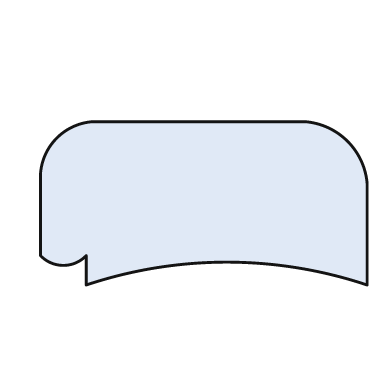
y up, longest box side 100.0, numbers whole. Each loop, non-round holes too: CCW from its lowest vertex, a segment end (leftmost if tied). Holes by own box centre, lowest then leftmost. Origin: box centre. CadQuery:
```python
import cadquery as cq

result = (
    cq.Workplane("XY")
    .moveTo(-36.0, -25.0)
    .threePointArc((7.0, -18.0), (50.0, -25.0))
    .lineTo(50.0, 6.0)
    .threePointArc((44.0, 19.0), (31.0, 25.0))
    .lineTo(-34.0, 25.0)
    .threePointArc((-45.0, 20.0), (-50.0, 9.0))
    .lineTo(-50.0, -16.0)
    .threePointArc((-43.0, -19.0), (-36.0, -16.0))
    .close()
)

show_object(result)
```